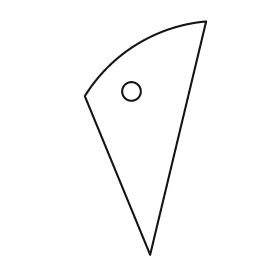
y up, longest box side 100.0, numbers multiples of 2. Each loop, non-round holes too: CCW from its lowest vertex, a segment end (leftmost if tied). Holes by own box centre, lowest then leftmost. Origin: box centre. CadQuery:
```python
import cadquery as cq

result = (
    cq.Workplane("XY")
    .moveTo(2.0, -50.0)
    .lineTo(26.0, 50.0)
    .threePointArc((-4.0, 40.0), (-26.0, 18.0))
    .close()
    .moveTo(-6.0, 20.0)
    .circle(4.0)
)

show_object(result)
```